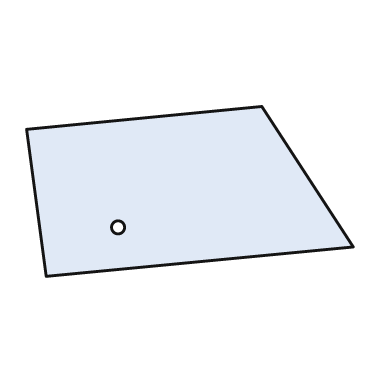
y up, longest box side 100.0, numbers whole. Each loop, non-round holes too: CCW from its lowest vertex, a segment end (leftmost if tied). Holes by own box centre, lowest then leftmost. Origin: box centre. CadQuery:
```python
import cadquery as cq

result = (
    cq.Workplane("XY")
    .moveTo(-44.0, -26.0)
    .lineTo(50.0, -17.0)
    .lineTo(22.0, 26.0)
    .lineTo(-50.0, 19.0)
    .close()
    .moveTo(-22.0, -11.0)
    .circle(2.0)
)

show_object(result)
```